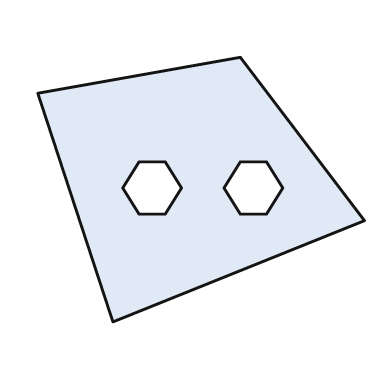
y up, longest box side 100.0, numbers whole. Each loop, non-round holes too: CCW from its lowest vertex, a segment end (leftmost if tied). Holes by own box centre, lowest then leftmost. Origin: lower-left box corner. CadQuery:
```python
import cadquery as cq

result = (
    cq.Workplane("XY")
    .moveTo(23.0, 0.0)
    .lineTo(100.0, 31.0)
    .lineTo(62.0, 81.0)
    .lineTo(0.0, 70.0)
    .close()
    .moveTo(31.0, 33.0)
    .lineTo(39.0, 33.0)
    .lineTo(44.0, 41.0)
    .lineTo(39.0, 49.0)
    .lineTo(31.0, 49.0)
    .lineTo(26.0, 41.0)
    .close()
    .moveTo(62.0, 33.0)
    .lineTo(70.0, 33.0)
    .lineTo(75.0, 41.0)
    .lineTo(70.0, 49.0)
    .lineTo(62.0, 49.0)
    .lineTo(57.0, 41.0)
    .close()
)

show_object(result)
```